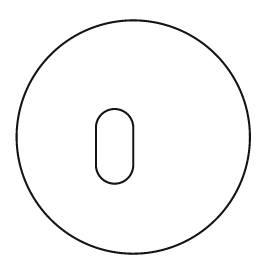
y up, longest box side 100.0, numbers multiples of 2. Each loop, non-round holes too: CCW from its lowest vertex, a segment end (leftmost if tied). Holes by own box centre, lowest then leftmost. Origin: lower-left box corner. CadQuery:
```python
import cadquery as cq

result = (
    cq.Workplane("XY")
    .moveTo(50.0, 50.0)
    .circle(50.0)
    .moveTo(34.0, 38.0)
    .threePointArc((42.0, 30.0), (50.0, 38.0))
    .lineTo(50.0, 54.0)
    .threePointArc((42.0, 62.0), (34.0, 54.0))
    .close()
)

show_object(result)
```